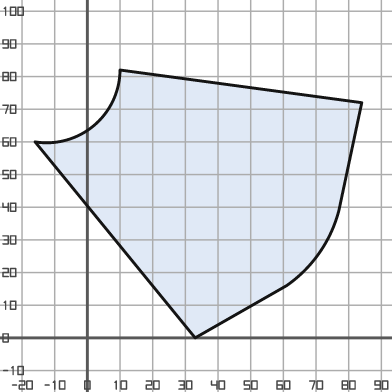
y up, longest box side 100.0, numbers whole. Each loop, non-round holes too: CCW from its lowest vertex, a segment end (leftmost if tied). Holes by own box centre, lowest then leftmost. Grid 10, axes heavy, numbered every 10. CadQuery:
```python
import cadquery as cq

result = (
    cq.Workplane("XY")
    .moveTo(33.0, 0.0)
    .lineTo(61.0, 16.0)
    .threePointArc((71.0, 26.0), (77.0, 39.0))
    .lineTo(84.0, 72.0)
    .lineTo(10.0, 82.0)
    .threePointArc((2.0, 65.0), (-16.0, 60.0))
    .close()
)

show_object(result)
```